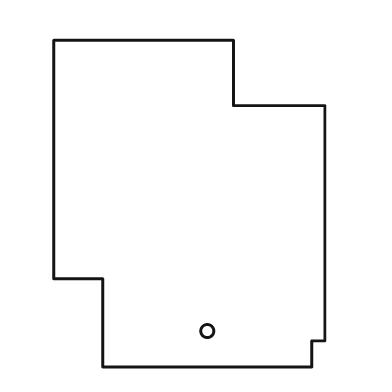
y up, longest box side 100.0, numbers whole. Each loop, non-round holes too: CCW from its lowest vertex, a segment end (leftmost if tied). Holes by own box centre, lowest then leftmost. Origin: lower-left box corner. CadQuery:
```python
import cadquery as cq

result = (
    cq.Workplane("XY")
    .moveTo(15.0, 0.0)
    .lineTo(79.0, 0.0)
    .lineTo(79.0, 8.0)
    .lineTo(83.0, 8.0)
    .lineTo(83.0, 80.0)
    .lineTo(55.0, 80.0)
    .lineTo(55.0, 100.0)
    .lineTo(0.0, 100.0)
    .lineTo(0.0, 27.0)
    .lineTo(15.0, 27.0)
    .close()
    .moveTo(47.0, 11.0)
    .circle(2.0)
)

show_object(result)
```